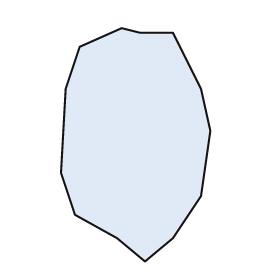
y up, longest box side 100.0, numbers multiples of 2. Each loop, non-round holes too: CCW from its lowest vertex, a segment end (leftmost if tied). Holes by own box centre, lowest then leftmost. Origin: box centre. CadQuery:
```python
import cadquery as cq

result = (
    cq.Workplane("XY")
    .moveTo(4.0, -50.0)
    .lineTo(16.0, -40.0)
    .lineTo(28.0, -22.0)
    .lineTo(32.0, 6.0)
    .lineTo(28.0, 24.0)
    .lineTo(16.0, 48.0)
    .lineTo(2.0, 48.0)
    .lineTo(-6.0, 50.0)
    .lineTo(-24.0, 42.0)
    .lineTo(-30.0, 24.0)
    .lineTo(-32.0, -12.0)
    .lineTo(-26.0, -30.0)
    .lineTo(-8.0, -40.0)
    .close()
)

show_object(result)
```